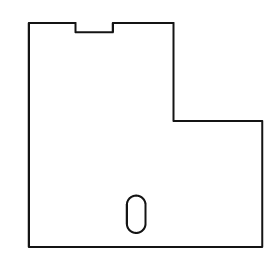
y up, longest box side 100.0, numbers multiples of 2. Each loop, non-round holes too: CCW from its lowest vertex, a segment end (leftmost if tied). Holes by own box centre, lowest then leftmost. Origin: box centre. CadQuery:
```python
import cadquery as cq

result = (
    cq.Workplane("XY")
    .moveTo(-50.0, -48.0)
    .lineTo(50.0, -48.0)
    .lineTo(50.0, 6.0)
    .lineTo(12.0, 6.0)
    .lineTo(12.0, 48.0)
    .lineTo(-14.0, 48.0)
    .lineTo(-14.0, 44.0)
    .lineTo(-30.0, 44.0)
    .lineTo(-30.0, 48.0)
    .lineTo(-50.0, 48.0)
    .close()
    .moveTo(-8.0, -38.0)
    .threePointArc((-4.0, -42.0), (0.0, -38.0))
    .lineTo(0.0, -30.0)
    .threePointArc((-4.0, -26.0), (-8.0, -30.0))
    .close()
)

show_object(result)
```